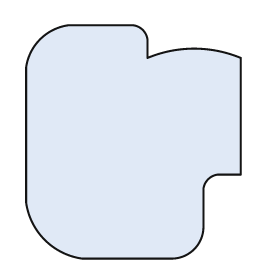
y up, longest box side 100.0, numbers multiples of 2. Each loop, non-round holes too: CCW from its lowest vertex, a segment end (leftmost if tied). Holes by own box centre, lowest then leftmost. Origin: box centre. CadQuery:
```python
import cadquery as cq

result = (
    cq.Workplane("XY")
    .moveTo(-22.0, -50.0)
    .lineTo(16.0, -50.0)
    .threePointArc((26.0, -46.0), (30.0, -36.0))
    .lineTo(30.0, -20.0)
    .threePointArc((32.0, -16.0), (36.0, -14.0))
    .lineTo(46.0, -14.0)
    .lineTo(46.0, 36.0)
    .threePointArc((26.0, 40.0), (6.0, 36.0))
    .lineTo(6.0, 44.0)
    .threePointArc((4.0, 48.0), (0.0, 50.0))
    .lineTo(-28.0, 50.0)
    .threePointArc((-40.0, 44.0), (-46.0, 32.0))
    .lineTo(-46.0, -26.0)
    .threePointArc((-38.0, -42.0), (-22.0, -50.0))
    .close()
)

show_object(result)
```